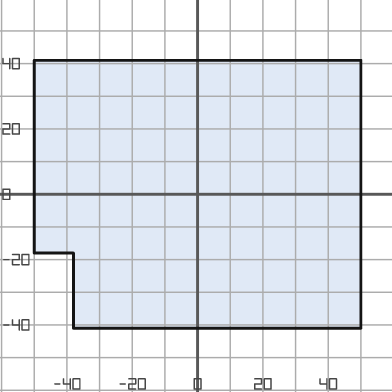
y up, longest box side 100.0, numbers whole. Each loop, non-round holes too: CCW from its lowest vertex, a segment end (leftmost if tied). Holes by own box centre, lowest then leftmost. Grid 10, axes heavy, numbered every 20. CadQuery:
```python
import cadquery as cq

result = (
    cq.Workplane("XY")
    .moveTo(-38.0, -41.0)
    .lineTo(50.0, -41.0)
    .lineTo(50.0, 41.0)
    .lineTo(-50.0, 41.0)
    .lineTo(-50.0, -18.0)
    .lineTo(-38.0, -18.0)
    .close()
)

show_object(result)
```